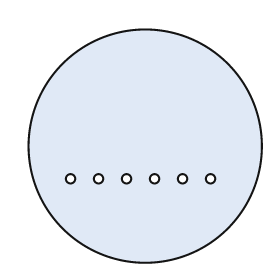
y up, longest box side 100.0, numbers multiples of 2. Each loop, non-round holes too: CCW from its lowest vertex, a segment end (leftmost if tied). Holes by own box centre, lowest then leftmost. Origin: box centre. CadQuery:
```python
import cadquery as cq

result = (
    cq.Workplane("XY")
    .moveTo(0.0, 0.0)
    .circle(50.0)
    .moveTo(-32.0, -14.0)
    .circle(2.0)
    .moveTo(-20.0, -14.0)
    .circle(2.0)
    .moveTo(-8.0, -14.0)
    .circle(2.0)
    .moveTo(4.0, -14.0)
    .circle(2.0)
    .moveTo(16.0, -14.0)
    .circle(2.0)
    .moveTo(28.0, -14.0)
    .circle(2.0)
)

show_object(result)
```